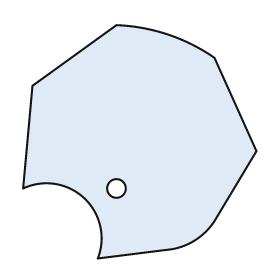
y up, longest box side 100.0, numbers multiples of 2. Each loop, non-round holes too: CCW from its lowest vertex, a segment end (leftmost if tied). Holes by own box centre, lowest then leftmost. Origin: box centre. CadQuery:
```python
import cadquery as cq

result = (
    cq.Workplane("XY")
    .moveTo(-18.0, -50.0)
    .lineTo(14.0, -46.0)
    .threePointArc((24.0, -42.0), (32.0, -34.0))
    .lineTo(50.0, -4.0)
    .lineTo(32.0, 36.0)
    .threePointArc((12.0, 46.0), (-10.0, 50.0))
    .lineTo(-46.0, 24.0)
    .lineTo(-50.0, -20.0)
    .threePointArc((-24.0, -24.0), (-18.0, -50.0))
    .close()
    .moveTo(-10.0, -20.0)
    .circle(4.0)
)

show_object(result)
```